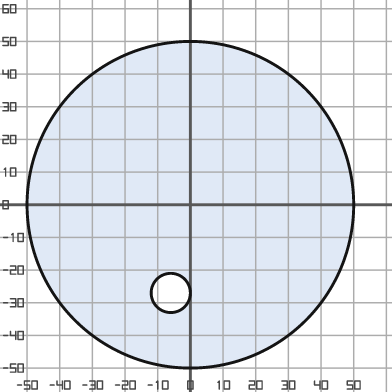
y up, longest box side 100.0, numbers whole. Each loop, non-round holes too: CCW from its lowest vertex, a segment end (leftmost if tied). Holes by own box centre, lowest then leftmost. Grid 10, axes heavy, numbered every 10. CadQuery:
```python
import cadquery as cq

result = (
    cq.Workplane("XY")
    .moveTo(0.0, 0.0)
    .circle(50.0)
    .moveTo(-6.0, -27.0)
    .circle(6.0)
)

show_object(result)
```